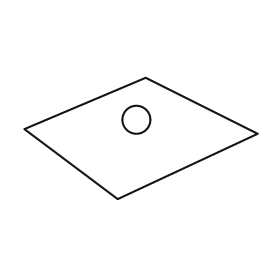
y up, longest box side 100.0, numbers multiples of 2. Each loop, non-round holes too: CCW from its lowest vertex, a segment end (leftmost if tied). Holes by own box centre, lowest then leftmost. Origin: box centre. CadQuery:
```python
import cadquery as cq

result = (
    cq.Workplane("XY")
    .moveTo(-10.0, -26.0)
    .lineTo(50.0, 2.0)
    .lineTo(2.0, 26.0)
    .lineTo(-50.0, 4.0)
    .close()
    .moveTo(-2.0, 8.0)
    .circle(6.0)
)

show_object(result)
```